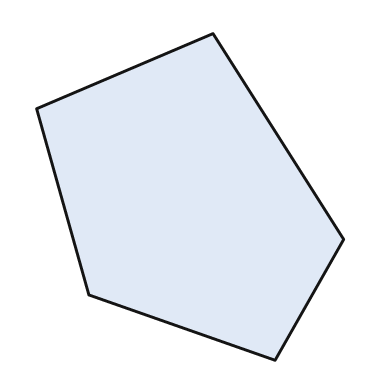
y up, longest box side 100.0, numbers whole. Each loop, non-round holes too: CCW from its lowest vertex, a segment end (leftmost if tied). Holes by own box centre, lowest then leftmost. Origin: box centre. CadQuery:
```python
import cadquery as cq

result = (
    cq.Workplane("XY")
    .moveTo(26.0, -50.0)
    .lineTo(47.0, -13.0)
    .lineTo(7.0, 50.0)
    .lineTo(-47.0, 27.0)
    .lineTo(-31.0, -30.0)
    .close()
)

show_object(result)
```